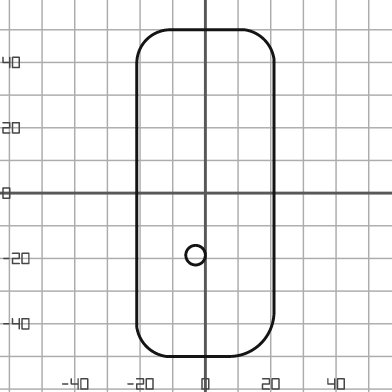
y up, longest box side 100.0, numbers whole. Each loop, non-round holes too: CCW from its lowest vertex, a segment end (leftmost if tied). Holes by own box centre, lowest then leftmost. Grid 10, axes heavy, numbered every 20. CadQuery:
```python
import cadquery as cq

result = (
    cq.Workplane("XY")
    .moveTo(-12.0, -50.0)
    .lineTo(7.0, -50.0)
    .threePointArc((17.0, -46.0), (21.0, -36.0))
    .lineTo(21.0, 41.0)
    .threePointArc((18.0, 47.0), (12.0, 50.0))
    .lineTo(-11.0, 50.0)
    .threePointArc((-18.0, 47.0), (-21.0, 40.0))
    .lineTo(-21.0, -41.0)
    .threePointArc((-18.0, -47.0), (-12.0, -50.0))
    .close()
    .moveTo(-3.0, -19.0)
    .circle(3.0)
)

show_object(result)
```